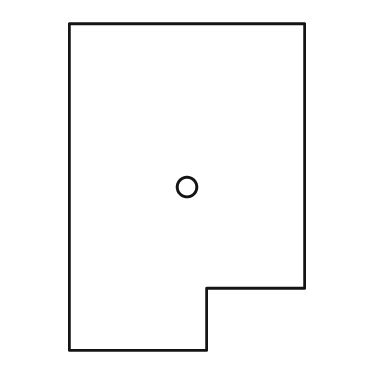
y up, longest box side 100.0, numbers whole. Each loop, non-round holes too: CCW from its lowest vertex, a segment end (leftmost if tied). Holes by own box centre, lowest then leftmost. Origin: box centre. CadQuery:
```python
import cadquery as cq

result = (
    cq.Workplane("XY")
    .moveTo(-36.0, -50.0)
    .lineTo(6.0, -50.0)
    .lineTo(6.0, -31.0)
    .lineTo(36.0, -31.0)
    .lineTo(36.0, 50.0)
    .lineTo(-36.0, 50.0)
    .close()
    .moveTo(0.0, 0.0)
    .circle(3.0)
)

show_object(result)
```